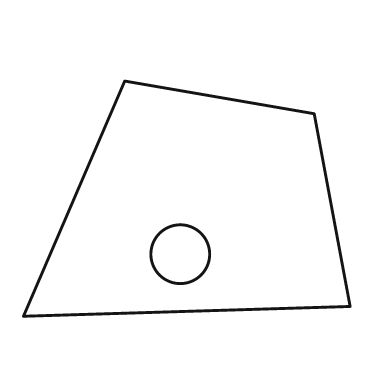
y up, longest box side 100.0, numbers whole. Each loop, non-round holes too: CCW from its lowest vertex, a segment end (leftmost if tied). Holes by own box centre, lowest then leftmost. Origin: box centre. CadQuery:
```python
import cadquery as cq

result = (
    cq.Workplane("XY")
    .moveTo(-50.0, -36.0)
    .lineTo(50.0, -33.0)
    .lineTo(39.0, 26.0)
    .lineTo(-19.0, 36.0)
    .close()
    .moveTo(-2.0, -17.0)
    .circle(9.0)
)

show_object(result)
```